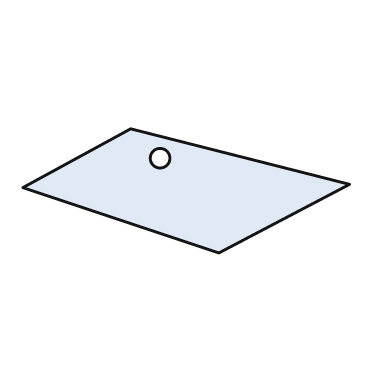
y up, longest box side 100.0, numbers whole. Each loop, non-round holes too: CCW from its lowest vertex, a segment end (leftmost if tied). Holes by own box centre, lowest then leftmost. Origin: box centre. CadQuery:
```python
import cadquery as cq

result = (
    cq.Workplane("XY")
    .moveTo(10.0, -19.0)
    .lineTo(50.0, 2.0)
    .lineTo(-17.0, 19.0)
    .lineTo(-50.0, 1.0)
    .close()
    .moveTo(-8.0, 10.0)
    .circle(3.0)
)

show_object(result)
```